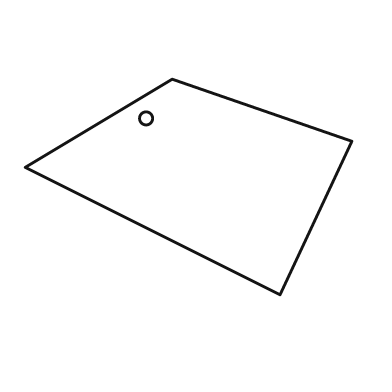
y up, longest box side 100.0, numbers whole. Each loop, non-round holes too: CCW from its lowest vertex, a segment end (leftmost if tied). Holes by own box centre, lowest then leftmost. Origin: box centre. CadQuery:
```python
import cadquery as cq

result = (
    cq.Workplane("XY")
    .moveTo(28.0, -33.0)
    .lineTo(50.0, 14.0)
    .lineTo(-5.0, 33.0)
    .lineTo(-50.0, 6.0)
    .close()
    .moveTo(-13.0, 21.0)
    .circle(2.0)
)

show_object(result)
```